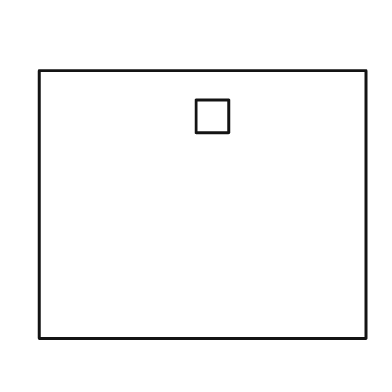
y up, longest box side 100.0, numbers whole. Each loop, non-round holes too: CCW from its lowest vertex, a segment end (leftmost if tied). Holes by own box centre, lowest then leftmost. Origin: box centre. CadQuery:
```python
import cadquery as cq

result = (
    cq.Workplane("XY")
    .moveTo(-50.0, -41.0)
    .lineTo(50.0, -41.0)
    .lineTo(50.0, 41.0)
    .lineTo(-50.0, 41.0)
    .close()
    .moveTo(-2.0, 22.0)
    .lineTo(8.0, 22.0)
    .lineTo(8.0, 32.0)
    .lineTo(-2.0, 32.0)
    .close()
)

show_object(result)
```